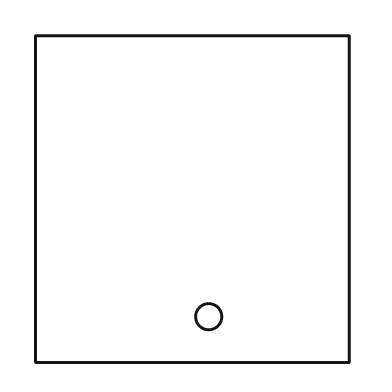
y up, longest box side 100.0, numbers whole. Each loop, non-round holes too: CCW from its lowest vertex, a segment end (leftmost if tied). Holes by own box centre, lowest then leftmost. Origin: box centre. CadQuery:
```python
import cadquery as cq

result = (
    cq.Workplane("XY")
    .moveTo(-48.0, -50.0)
    .lineTo(48.0, -50.0)
    .lineTo(48.0, 50.0)
    .lineTo(-48.0, 50.0)
    .close()
    .moveTo(5.0, -36.0)
    .circle(4.0)
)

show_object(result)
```